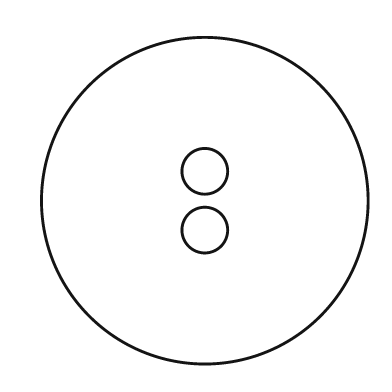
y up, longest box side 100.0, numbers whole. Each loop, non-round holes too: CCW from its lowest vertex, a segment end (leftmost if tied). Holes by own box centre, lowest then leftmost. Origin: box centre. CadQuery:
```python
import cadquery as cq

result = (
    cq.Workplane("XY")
    .moveTo(0.0, 0.0)
    .circle(50.0)
    .moveTo(0.0, -9.0)
    .circle(7.0)
    .moveTo(0.0, 9.0)
    .circle(7.0)
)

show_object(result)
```